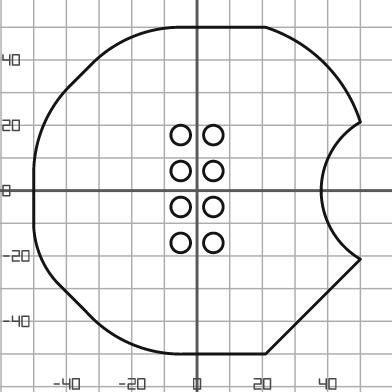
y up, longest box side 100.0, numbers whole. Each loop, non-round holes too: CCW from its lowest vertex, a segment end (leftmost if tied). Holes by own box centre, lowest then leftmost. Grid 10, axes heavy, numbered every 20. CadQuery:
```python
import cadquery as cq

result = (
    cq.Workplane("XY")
    .moveTo(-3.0, -50.0)
    .lineTo(21.0, -50.0)
    .lineTo(50.0, -21.0)
    .threePointArc((38.0, 0.0), (50.0, 21.0))
    .threePointArc((39.0, 39.0), (21.0, 50.0))
    .lineTo(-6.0, 50.0)
    .threePointArc((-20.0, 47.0), (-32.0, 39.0))
    .lineTo(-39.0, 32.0)
    .threePointArc((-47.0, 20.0), (-50.0, 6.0))
    .lineTo(-50.0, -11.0)
    .threePointArc((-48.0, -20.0), (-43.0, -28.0))
    .lineTo(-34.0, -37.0)
    .threePointArc((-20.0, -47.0), (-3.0, -50.0))
    .close()
    .moveTo(-5.0, -16.0)
    .circle(3.0)
    .moveTo(5.0, -16.0)
    .circle(3.0)
    .moveTo(-5.0, -5.0)
    .circle(3.0)
    .moveTo(5.0, -5.0)
    .circle(3.0)
    .moveTo(-5.0, 6.0)
    .circle(3.0)
    .moveTo(5.0, 6.0)
    .circle(3.0)
    .moveTo(-5.0, 17.0)
    .circle(3.0)
    .moveTo(5.0, 17.0)
    .circle(3.0)
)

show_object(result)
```